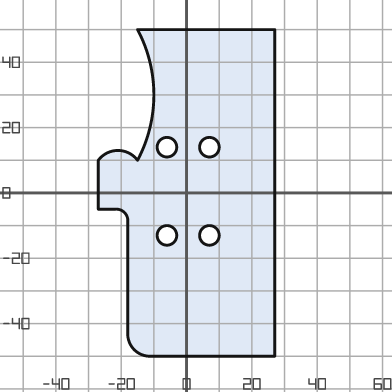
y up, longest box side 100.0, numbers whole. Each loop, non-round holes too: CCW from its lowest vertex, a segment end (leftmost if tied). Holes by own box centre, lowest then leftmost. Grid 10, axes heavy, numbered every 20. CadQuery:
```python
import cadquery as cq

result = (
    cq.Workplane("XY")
    .moveTo(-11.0, -50.0)
    .lineTo(27.0, -50.0)
    .lineTo(27.0, 50.0)
    .lineTo(-15.0, 50.0)
    .threePointArc((-10.0, 30.0), (-15.0, 10.0))
    .threePointArc((-21.0, 13.0), (-27.0, 10.0))
    .lineTo(-27.0, -5.0)
    .lineTo(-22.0, -5.0)
    .threePointArc((-19.0, -6.0), (-18.0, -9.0))
    .lineTo(-18.0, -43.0)
    .threePointArc((-16.0, -48.0), (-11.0, -50.0))
    .close()
    .moveTo(-6.0, -13.0)
    .circle(3.0)
    .moveTo(7.0, -13.0)
    .circle(3.0)
    .moveTo(-6.0, 14.0)
    .circle(3.0)
    .moveTo(7.0, 14.0)
    .circle(3.0)
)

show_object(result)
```